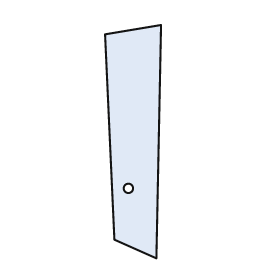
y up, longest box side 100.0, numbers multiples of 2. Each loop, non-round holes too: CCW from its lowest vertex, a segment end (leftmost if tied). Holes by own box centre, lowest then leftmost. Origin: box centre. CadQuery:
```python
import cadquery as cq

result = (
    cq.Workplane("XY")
    .moveTo(10.0, -50.0)
    .lineTo(12.0, 50.0)
    .lineTo(-12.0, 46.0)
    .lineTo(-8.0, -42.0)
    .close()
    .moveTo(-2.0, -20.0)
    .circle(2.0)
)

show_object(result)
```